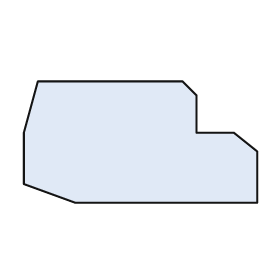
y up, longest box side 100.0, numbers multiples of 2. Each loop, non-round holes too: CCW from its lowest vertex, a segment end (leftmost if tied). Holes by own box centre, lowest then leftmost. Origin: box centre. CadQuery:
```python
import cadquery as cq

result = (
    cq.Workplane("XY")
    .moveTo(-28.0, -26.0)
    .lineTo(50.0, -26.0)
    .lineTo(50.0, -4.0)
    .lineTo(40.0, 4.0)
    .lineTo(24.0, 4.0)
    .lineTo(24.0, 20.0)
    .lineTo(18.0, 26.0)
    .lineTo(-44.0, 26.0)
    .lineTo(-50.0, 4.0)
    .lineTo(-50.0, -18.0)
    .close()
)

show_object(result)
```